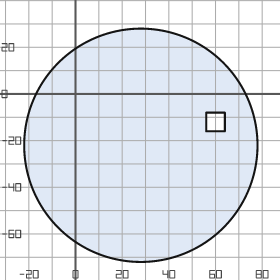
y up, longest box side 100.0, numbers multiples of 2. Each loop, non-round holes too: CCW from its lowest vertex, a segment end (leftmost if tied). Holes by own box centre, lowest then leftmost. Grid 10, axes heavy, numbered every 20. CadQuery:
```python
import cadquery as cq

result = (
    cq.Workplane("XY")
    .moveTo(28.0, -22.0)
    .circle(50.0)
    .moveTo(56.0, -16.0)
    .lineTo(64.0, -16.0)
    .lineTo(64.0, -8.0)
    .lineTo(56.0, -8.0)
    .close()
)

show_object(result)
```